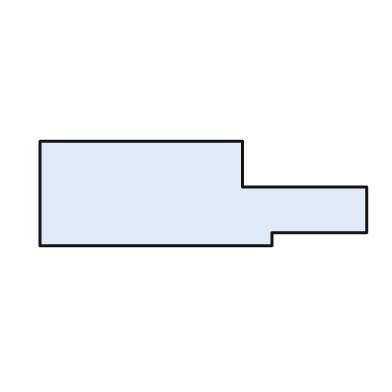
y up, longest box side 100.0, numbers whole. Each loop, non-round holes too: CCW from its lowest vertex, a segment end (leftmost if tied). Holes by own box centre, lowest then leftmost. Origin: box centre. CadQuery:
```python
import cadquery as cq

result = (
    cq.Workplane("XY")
    .moveTo(-50.0, -16.0)
    .lineTo(21.0, -16.0)
    .lineTo(21.0, -12.0)
    .lineTo(50.0, -12.0)
    .lineTo(50.0, 2.0)
    .lineTo(12.0, 2.0)
    .lineTo(12.0, 16.0)
    .lineTo(-50.0, 16.0)
    .close()
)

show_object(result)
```